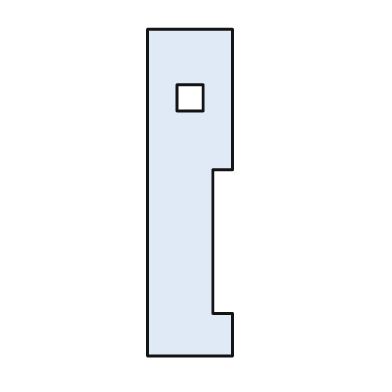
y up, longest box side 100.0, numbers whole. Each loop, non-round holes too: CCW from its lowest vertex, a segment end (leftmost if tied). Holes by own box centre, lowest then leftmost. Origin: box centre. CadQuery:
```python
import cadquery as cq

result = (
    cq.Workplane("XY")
    .moveTo(-13.0, -50.0)
    .lineTo(13.0, -50.0)
    .lineTo(13.0, -37.0)
    .lineTo(7.0, -37.0)
    .lineTo(7.0, 7.0)
    .lineTo(13.0, 7.0)
    .lineTo(13.0, 50.0)
    .lineTo(-13.0, 50.0)
    .close()
    .moveTo(-4.0, 25.0)
    .lineTo(4.0, 25.0)
    .lineTo(4.0, 33.0)
    .lineTo(-4.0, 33.0)
    .close()
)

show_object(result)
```